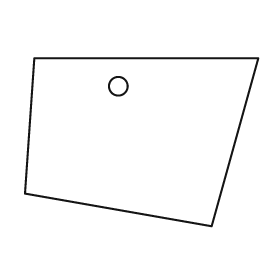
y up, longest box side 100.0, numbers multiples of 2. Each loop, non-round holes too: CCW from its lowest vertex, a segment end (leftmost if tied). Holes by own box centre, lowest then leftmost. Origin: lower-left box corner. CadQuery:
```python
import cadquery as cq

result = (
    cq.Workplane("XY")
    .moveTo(80.0, 0.0)
    .lineTo(100.0, 72.0)
    .lineTo(4.0, 72.0)
    .lineTo(0.0, 14.0)
    .close()
    .moveTo(40.0, 60.0)
    .circle(4.0)
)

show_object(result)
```